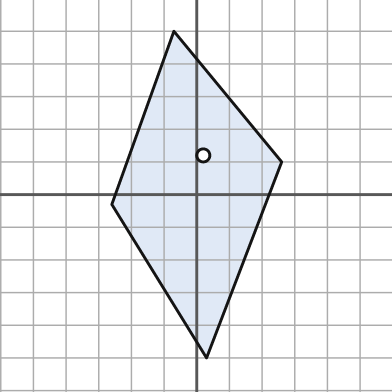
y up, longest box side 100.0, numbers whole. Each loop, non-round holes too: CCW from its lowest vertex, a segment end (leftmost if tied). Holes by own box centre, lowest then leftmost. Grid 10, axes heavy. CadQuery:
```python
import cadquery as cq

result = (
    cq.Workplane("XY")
    .moveTo(3.0, -50.0)
    .lineTo(26.0, 10.0)
    .lineTo(-7.0, 50.0)
    .lineTo(-26.0, -3.0)
    .close()
    .moveTo(2.0, 12.0)
    .circle(2.0)
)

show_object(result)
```